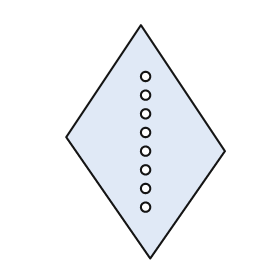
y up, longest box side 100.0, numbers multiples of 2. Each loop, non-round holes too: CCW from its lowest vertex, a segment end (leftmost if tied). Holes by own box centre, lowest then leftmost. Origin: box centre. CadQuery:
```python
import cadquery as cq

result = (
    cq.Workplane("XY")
    .moveTo(2.0, -50.0)
    .lineTo(34.0, -4.0)
    .lineTo(-2.0, 50.0)
    .lineTo(-34.0, 2.0)
    .close()
    .moveTo(0.0, -28.0)
    .circle(2.0)
    .moveTo(0.0, -20.0)
    .circle(2.0)
    .moveTo(0.0, -12.0)
    .circle(2.0)
    .moveTo(0.0, -4.0)
    .circle(2.0)
    .moveTo(0.0, 4.0)
    .circle(2.0)
    .moveTo(0.0, 12.0)
    .circle(2.0)
    .moveTo(0.0, 20.0)
    .circle(2.0)
    .moveTo(0.0, 28.0)
    .circle(2.0)
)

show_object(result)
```